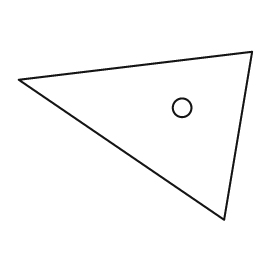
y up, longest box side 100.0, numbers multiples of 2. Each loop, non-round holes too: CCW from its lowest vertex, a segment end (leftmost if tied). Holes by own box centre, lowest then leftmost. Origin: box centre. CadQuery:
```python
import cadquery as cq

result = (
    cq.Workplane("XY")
    .moveTo(38.0, -36.0)
    .lineTo(50.0, 36.0)
    .lineTo(-50.0, 24.0)
    .close()
    .moveTo(20.0, 12.0)
    .circle(4.0)
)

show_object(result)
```